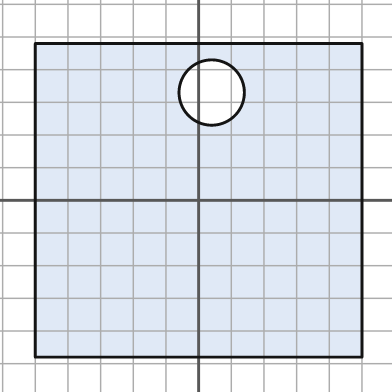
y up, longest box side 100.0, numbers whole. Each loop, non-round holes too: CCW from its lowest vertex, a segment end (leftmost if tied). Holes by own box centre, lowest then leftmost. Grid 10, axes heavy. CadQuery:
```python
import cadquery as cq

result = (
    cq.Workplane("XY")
    .moveTo(-50.0, -48.0)
    .lineTo(50.0, -48.0)
    .lineTo(50.0, 48.0)
    .lineTo(-50.0, 48.0)
    .close()
    .moveTo(4.0, 33.0)
    .circle(10.0)
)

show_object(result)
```